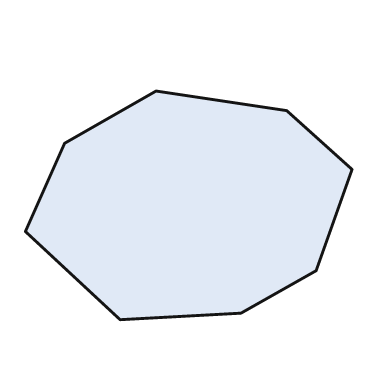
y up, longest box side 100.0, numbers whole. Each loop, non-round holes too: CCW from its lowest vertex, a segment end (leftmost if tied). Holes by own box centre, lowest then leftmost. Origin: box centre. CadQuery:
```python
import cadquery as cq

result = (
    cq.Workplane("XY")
    .moveTo(-21.0, -35.0)
    .lineTo(16.0, -33.0)
    .lineTo(39.0, -20.0)
    .lineTo(50.0, 11.0)
    .lineTo(30.0, 29.0)
    .lineTo(-10.0, 35.0)
    .lineTo(-38.0, 19.0)
    .lineTo(-50.0, -8.0)
    .close()
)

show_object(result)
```